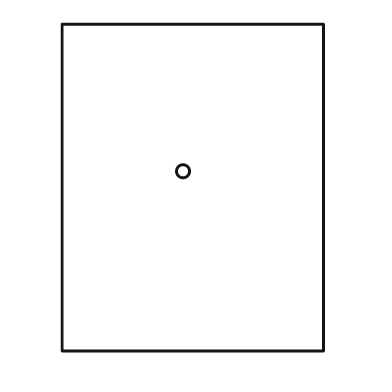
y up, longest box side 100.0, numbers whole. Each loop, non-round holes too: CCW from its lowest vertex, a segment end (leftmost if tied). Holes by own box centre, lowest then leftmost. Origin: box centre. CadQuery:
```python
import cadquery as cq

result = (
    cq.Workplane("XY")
    .moveTo(-40.0, -50.0)
    .lineTo(40.0, -50.0)
    .lineTo(40.0, 50.0)
    .lineTo(-40.0, 50.0)
    .close()
    .moveTo(-3.0, 5.0)
    .circle(2.0)
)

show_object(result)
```